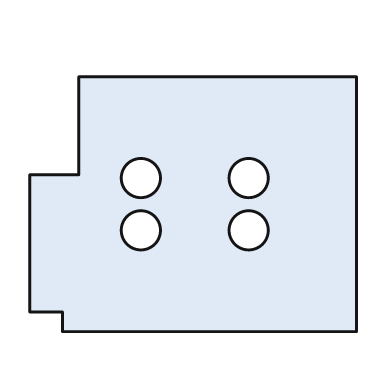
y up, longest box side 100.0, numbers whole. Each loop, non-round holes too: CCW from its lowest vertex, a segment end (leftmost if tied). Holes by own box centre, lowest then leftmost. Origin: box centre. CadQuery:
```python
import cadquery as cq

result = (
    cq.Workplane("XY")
    .moveTo(-40.0, -39.0)
    .lineTo(50.0, -39.0)
    .lineTo(50.0, 39.0)
    .lineTo(-35.0, 39.0)
    .lineTo(-35.0, 9.0)
    .lineTo(-50.0, 9.0)
    .lineTo(-50.0, -33.0)
    .lineTo(-40.0, -33.0)
    .close()
    .moveTo(-16.0, -8.0)
    .circle(6.0)
    .moveTo(17.0, -8.0)
    .circle(6.0)
    .moveTo(-16.0, 8.0)
    .circle(6.0)
    .moveTo(17.0, 8.0)
    .circle(6.0)
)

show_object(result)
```